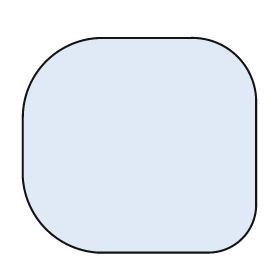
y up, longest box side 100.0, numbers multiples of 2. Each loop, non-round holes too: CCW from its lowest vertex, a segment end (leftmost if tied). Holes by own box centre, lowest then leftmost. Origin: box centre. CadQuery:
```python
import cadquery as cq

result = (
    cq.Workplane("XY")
    .moveTo(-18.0, -46.0)
    .lineTo(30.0, -46.0)
    .threePointArc((44.0, -40.0), (50.0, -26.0))
    .lineTo(50.0, 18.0)
    .threePointArc((42.0, 38.0), (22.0, 46.0))
    .lineTo(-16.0, 46.0)
    .threePointArc((-40.0, 36.0), (-50.0, 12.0))
    .lineTo(-50.0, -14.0)
    .threePointArc((-40.0, -36.0), (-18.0, -46.0))
    .close()
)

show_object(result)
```